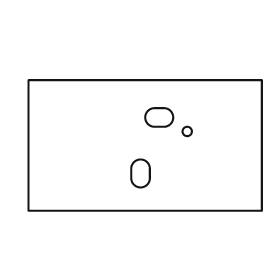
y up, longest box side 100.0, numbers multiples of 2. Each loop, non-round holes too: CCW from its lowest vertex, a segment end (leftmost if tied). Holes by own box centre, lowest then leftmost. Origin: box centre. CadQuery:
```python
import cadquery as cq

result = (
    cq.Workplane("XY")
    .moveTo(-50.0, -28.0)
    .lineTo(50.0, -28.0)
    .lineTo(50.0, 28.0)
    .lineTo(-50.0, 28.0)
    .close()
    .moveTo(-6.0, -14.0)
    .threePointArc((-2.0, -18.0), (2.0, -14.0))
    .lineTo(2.0, -10.0)
    .threePointArc((-2.0, -6.0), (-6.0, -10.0))
    .close()
    .moveTo(18.0, 6.0)
    .circle(2.0)
    .moveTo(4.0, 8.0)
    .lineTo(8.0, 8.0)
    .threePointArc((12.0, 12.0), (8.0, 16.0))
    .lineTo(4.0, 16.0)
    .threePointArc((0.0, 12.0), (4.0, 8.0))
    .close()
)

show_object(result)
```